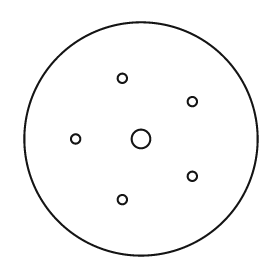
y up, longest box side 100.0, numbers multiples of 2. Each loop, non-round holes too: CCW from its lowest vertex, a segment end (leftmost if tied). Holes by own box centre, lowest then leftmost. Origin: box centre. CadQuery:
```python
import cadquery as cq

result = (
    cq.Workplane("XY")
    .moveTo(0.0, 0.0)
    .circle(50.0)
    .moveTo(-8.0, -26.0)
    .circle(2.0)
    .moveTo(22.0, -16.0)
    .circle(2.0)
    .moveTo(-28.0, 0.0)
    .circle(2.0)
    .moveTo(0.0, 0.0)
    .circle(4.0)
    .moveTo(22.0, 16.0)
    .circle(2.0)
    .moveTo(-8.0, 26.0)
    .circle(2.0)
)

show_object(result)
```